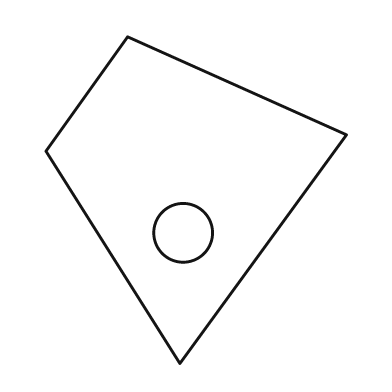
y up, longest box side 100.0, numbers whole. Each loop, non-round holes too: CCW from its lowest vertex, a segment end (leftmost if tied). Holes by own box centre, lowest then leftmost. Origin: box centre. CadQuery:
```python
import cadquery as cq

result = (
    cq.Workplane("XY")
    .moveTo(-5.0, -50.0)
    .lineTo(46.0, 20.0)
    .lineTo(-21.0, 50.0)
    .lineTo(-46.0, 15.0)
    .close()
    .moveTo(-4.0, -10.0)
    .circle(9.0)
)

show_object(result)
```